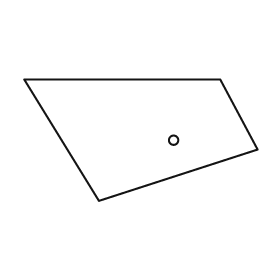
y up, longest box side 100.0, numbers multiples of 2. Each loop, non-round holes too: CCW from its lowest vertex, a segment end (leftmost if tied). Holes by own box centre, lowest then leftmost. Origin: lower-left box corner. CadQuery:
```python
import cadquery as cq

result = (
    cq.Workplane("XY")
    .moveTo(32.0, 0.0)
    .lineTo(100.0, 22.0)
    .lineTo(84.0, 52.0)
    .lineTo(0.0, 52.0)
    .close()
    .moveTo(64.0, 26.0)
    .circle(2.0)
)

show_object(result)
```